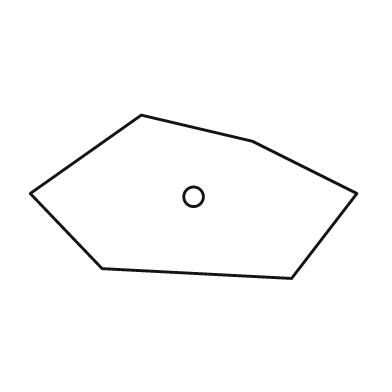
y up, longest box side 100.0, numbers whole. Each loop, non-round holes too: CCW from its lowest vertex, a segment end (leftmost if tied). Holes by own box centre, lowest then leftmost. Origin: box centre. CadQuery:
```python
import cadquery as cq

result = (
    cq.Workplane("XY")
    .moveTo(30.0, -25.0)
    .lineTo(50.0, 1.0)
    .lineTo(18.0, 17.0)
    .lineTo(-16.0, 25.0)
    .lineTo(-50.0, 1.0)
    .lineTo(-28.0, -22.0)
    .close()
    .moveTo(0.0, 0.0)
    .circle(3.0)
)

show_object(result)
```